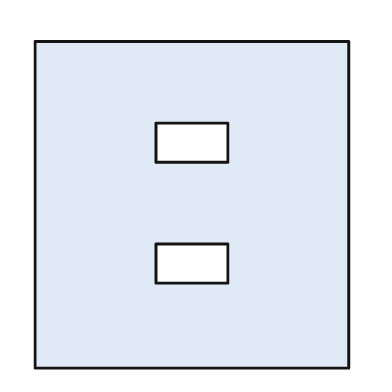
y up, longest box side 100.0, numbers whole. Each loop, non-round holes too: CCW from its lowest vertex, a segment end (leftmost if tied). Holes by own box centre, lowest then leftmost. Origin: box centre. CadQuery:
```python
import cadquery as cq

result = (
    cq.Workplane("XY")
    .moveTo(-48.0, -50.0)
    .lineTo(48.0, -50.0)
    .lineTo(48.0, 50.0)
    .lineTo(-48.0, 50.0)
    .close()
    .moveTo(-11.0, -24.0)
    .lineTo(11.0, -24.0)
    .lineTo(11.0, -12.0)
    .lineTo(-11.0, -12.0)
    .close()
    .moveTo(-11.0, 13.0)
    .lineTo(11.0, 13.0)
    .lineTo(11.0, 25.0)
    .lineTo(-11.0, 25.0)
    .close()
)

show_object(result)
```